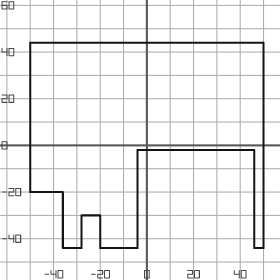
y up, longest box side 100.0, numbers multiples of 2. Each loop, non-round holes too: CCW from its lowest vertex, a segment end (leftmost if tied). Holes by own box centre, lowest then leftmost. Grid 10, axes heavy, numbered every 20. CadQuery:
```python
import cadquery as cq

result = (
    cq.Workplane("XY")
    .moveTo(-36.0, -44.0)
    .lineTo(-28.0, -44.0)
    .lineTo(-28.0, -30.0)
    .lineTo(-20.0, -30.0)
    .lineTo(-20.0, -44.0)
    .lineTo(-4.0, -44.0)
    .lineTo(-4.0, -2.0)
    .lineTo(46.0, -2.0)
    .lineTo(46.0, -44.0)
    .lineTo(50.0, -44.0)
    .lineTo(50.0, 44.0)
    .lineTo(-50.0, 44.0)
    .lineTo(-50.0, -20.0)
    .lineTo(-36.0, -20.0)
    .close()
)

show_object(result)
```